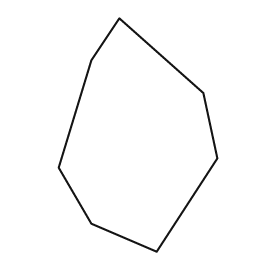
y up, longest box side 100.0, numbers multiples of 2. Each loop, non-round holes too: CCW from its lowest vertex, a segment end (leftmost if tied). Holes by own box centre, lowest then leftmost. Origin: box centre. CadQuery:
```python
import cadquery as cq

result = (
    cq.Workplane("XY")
    .moveTo(8.0, -50.0)
    .lineTo(34.0, -10.0)
    .lineTo(28.0, 18.0)
    .lineTo(-8.0, 50.0)
    .lineTo(-20.0, 32.0)
    .lineTo(-34.0, -14.0)
    .lineTo(-20.0, -38.0)
    .close()
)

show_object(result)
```